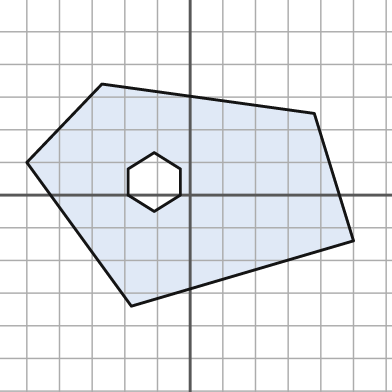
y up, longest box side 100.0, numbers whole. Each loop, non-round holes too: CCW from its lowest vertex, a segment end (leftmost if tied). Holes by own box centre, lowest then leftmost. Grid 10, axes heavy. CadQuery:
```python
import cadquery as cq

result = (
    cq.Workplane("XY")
    .moveTo(-18.0, -34.0)
    .lineTo(50.0, -14.0)
    .lineTo(38.0, 25.0)
    .lineTo(-27.0, 34.0)
    .lineTo(-50.0, 10.0)
    .close()
    .moveTo(-11.0, -5.0)
    .lineTo(-3.0, 0.0)
    .lineTo(-3.0, 8.0)
    .lineTo(-11.0, 13.0)
    .lineTo(-19.0, 8.0)
    .lineTo(-19.0, 0.0)
    .close()
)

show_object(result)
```